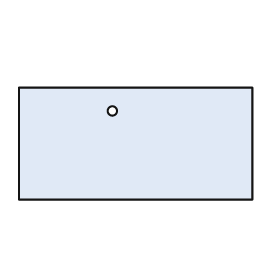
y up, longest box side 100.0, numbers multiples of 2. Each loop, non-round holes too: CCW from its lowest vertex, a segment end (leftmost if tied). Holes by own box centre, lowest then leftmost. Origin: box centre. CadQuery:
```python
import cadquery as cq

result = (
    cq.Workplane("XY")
    .moveTo(-50.0, -24.0)
    .lineTo(50.0, -24.0)
    .lineTo(50.0, 24.0)
    .lineTo(-50.0, 24.0)
    .close()
    .moveTo(-10.0, 14.0)
    .circle(2.0)
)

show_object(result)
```